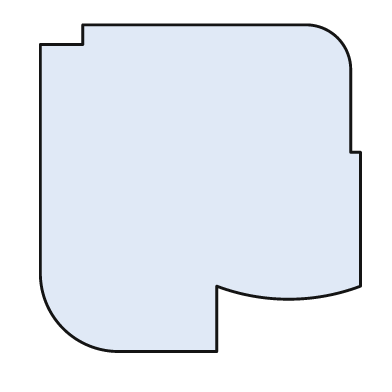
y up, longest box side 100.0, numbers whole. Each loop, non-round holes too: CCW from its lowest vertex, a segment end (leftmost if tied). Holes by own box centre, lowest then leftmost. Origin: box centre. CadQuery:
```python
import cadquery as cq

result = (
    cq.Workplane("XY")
    .moveTo(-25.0, -50.0)
    .lineTo(5.0, -50.0)
    .lineTo(5.0, -30.0)
    .threePointArc((27.0, -34.0), (49.0, -30.0))
    .lineTo(49.0, 11.0)
    .lineTo(46.0, 11.0)
    .lineTo(46.0, 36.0)
    .threePointArc((42.0, 46.0), (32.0, 50.0))
    .lineTo(-36.0, 50.0)
    .lineTo(-36.0, 44.0)
    .lineTo(-49.0, 44.0)
    .lineTo(-49.0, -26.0)
    .threePointArc((-42.0, -43.0), (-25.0, -50.0))
    .close()
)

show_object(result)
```